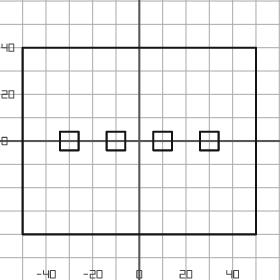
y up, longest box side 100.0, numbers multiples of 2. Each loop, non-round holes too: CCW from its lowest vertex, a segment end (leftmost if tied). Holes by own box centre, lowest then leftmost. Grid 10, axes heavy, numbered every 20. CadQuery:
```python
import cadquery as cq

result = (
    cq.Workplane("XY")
    .moveTo(-50.0, -40.0)
    .lineTo(50.0, -40.0)
    .lineTo(50.0, 40.0)
    .lineTo(-50.0, 40.0)
    .close()
    .moveTo(-34.0, -4.0)
    .lineTo(-26.0, -4.0)
    .lineTo(-26.0, 4.0)
    .lineTo(-34.0, 4.0)
    .close()
    .moveTo(-14.0, -4.0)
    .lineTo(-6.0, -4.0)
    .lineTo(-6.0, 4.0)
    .lineTo(-14.0, 4.0)
    .close()
    .moveTo(6.0, -4.0)
    .lineTo(14.0, -4.0)
    .lineTo(14.0, 4.0)
    .lineTo(6.0, 4.0)
    .close()
    .moveTo(26.0, -4.0)
    .lineTo(34.0, -4.0)
    .lineTo(34.0, 4.0)
    .lineTo(26.0, 4.0)
    .close()
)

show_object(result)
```